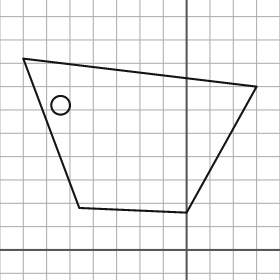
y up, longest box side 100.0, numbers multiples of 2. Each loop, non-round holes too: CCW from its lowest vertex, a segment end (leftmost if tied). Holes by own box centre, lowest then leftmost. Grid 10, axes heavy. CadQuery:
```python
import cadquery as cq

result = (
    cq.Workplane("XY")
    .moveTo(0.0, 16.0)
    .lineTo(30.0, 70.0)
    .lineTo(-70.0, 82.0)
    .lineTo(-46.0, 18.0)
    .close()
    .moveTo(-54.0, 62.0)
    .circle(4.0)
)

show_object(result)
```